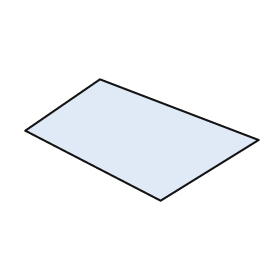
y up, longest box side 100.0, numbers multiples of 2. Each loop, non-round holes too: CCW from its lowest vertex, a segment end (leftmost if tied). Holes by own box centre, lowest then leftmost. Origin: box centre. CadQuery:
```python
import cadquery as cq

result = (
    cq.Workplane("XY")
    .moveTo(8.0, -26.0)
    .lineTo(50.0, 0.0)
    .lineTo(-18.0, 26.0)
    .lineTo(-50.0, 4.0)
    .close()
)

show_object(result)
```